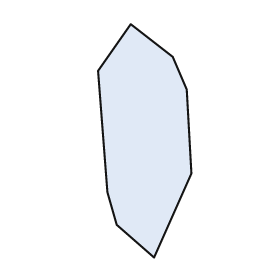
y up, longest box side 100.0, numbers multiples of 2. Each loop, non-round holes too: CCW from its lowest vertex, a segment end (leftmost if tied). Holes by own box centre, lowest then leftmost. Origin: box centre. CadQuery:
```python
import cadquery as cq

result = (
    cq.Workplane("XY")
    .moveTo(4.0, -50.0)
    .lineTo(20.0, -14.0)
    .lineTo(18.0, 22.0)
    .lineTo(12.0, 36.0)
    .lineTo(-6.0, 50.0)
    .lineTo(-20.0, 30.0)
    .lineTo(-16.0, -22.0)
    .lineTo(-12.0, -36.0)
    .close()
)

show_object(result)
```